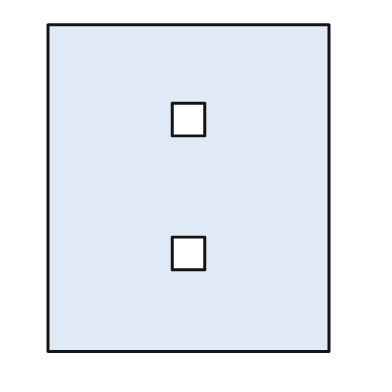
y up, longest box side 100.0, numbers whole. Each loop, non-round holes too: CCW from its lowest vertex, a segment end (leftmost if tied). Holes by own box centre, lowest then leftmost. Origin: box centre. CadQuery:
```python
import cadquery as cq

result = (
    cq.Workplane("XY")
    .moveTo(-43.0, -50.0)
    .lineTo(43.0, -50.0)
    .lineTo(43.0, 50.0)
    .lineTo(-43.0, 50.0)
    .close()
    .moveTo(-5.0, -25.0)
    .lineTo(5.0, -25.0)
    .lineTo(5.0, -15.0)
    .lineTo(-5.0, -15.0)
    .close()
    .moveTo(-5.0, 16.0)
    .lineTo(5.0, 16.0)
    .lineTo(5.0, 26.0)
    .lineTo(-5.0, 26.0)
    .close()
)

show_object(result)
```